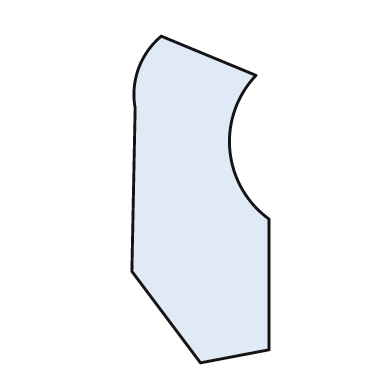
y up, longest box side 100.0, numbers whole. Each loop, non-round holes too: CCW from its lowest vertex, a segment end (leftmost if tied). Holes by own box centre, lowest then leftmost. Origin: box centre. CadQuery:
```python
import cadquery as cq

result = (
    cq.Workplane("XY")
    .moveTo(0.0, -50.0)
    .lineTo(21.0, -46.0)
    .lineTo(21.0, -6.0)
    .threePointArc((9.0, 15.0), (17.0, 38.0))
    .lineTo(-12.0, 50.0)
    .threePointArc((-19.0, 40.0), (-20.0, 28.0))
    .lineTo(-21.0, -22.0)
    .close()
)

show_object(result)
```